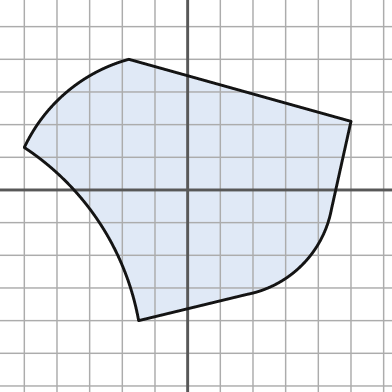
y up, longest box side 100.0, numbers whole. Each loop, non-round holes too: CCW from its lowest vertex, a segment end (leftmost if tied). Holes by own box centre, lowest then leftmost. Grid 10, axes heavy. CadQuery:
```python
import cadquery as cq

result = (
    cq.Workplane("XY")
    .moveTo(-15.0, -40.0)
    .lineTo(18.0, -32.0)
    .threePointArc((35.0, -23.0), (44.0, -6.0))
    .lineTo(50.0, 21.0)
    .lineTo(-18.0, 40.0)
    .threePointArc((-37.0, 30.0), (-50.0, 13.0))
    .threePointArc((-27.0, -10.0), (-15.0, -40.0))
    .close()
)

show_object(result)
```